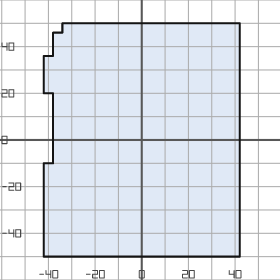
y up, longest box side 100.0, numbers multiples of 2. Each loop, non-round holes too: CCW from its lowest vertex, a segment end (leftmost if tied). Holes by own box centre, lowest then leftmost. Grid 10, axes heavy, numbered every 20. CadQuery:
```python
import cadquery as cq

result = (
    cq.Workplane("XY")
    .moveTo(-42.0, -50.0)
    .lineTo(42.0, -50.0)
    .lineTo(42.0, 50.0)
    .lineTo(-34.0, 50.0)
    .lineTo(-34.0, 46.0)
    .lineTo(-38.0, 46.0)
    .lineTo(-38.0, 36.0)
    .lineTo(-42.0, 36.0)
    .lineTo(-42.0, 20.0)
    .lineTo(-38.0, 20.0)
    .lineTo(-38.0, -10.0)
    .lineTo(-42.0, -10.0)
    .close()
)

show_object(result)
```